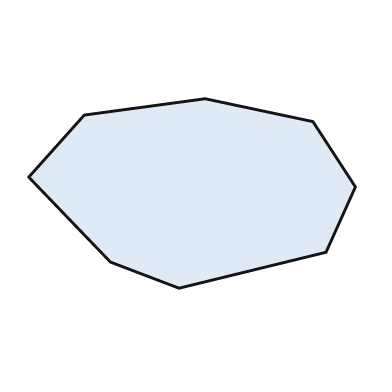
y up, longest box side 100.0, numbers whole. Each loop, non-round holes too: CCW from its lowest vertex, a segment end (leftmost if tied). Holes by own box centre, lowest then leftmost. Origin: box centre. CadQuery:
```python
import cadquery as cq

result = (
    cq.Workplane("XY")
    .moveTo(-4.0, -29.0)
    .lineTo(41.0, -18.0)
    .lineTo(50.0, 2.0)
    .lineTo(37.0, 22.0)
    .lineTo(4.0, 29.0)
    .lineTo(-33.0, 24.0)
    .lineTo(-50.0, 5.0)
    .lineTo(-25.0, -21.0)
    .close()
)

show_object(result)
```